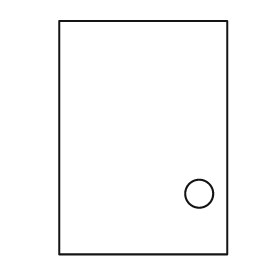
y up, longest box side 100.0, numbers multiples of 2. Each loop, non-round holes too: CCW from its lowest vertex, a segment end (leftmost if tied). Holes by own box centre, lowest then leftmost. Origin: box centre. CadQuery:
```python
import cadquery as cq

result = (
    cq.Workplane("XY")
    .moveTo(-36.0, -50.0)
    .lineTo(36.0, -50.0)
    .lineTo(36.0, 50.0)
    .lineTo(-36.0, 50.0)
    .close()
    .moveTo(24.0, -24.0)
    .circle(6.0)
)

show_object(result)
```